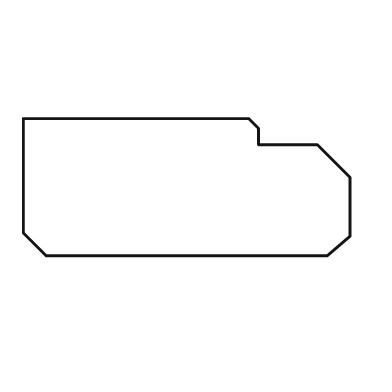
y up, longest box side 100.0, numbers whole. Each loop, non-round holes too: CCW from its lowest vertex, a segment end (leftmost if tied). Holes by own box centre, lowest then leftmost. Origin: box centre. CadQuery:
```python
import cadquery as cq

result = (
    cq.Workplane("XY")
    .moveTo(-43.0, -21.0)
    .lineTo(43.0, -21.0)
    .lineTo(50.0, -15.0)
    .lineTo(50.0, 3.0)
    .lineTo(40.0, 13.0)
    .lineTo(22.0, 13.0)
    .lineTo(22.0, 18.0)
    .lineTo(19.0, 21.0)
    .lineTo(-50.0, 21.0)
    .lineTo(-50.0, -14.0)
    .close()
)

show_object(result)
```